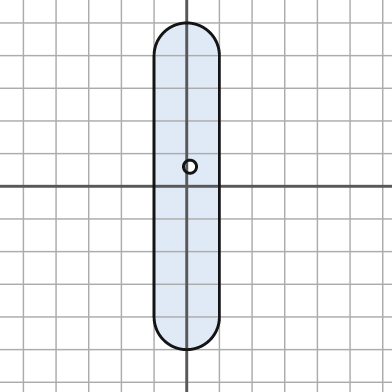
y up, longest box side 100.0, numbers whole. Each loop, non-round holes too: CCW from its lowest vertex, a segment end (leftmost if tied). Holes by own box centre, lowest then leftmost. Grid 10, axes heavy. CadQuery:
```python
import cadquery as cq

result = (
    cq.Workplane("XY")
    .moveTo(-10.0, -40.0)
    .threePointArc((0.0, -50.0), (10.0, -40.0))
    .lineTo(10.0, 40.0)
    .threePointArc((0.0, 50.0), (-10.0, 40.0))
    .close()
    .moveTo(1.0, 6.0)
    .circle(2.0)
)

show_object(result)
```